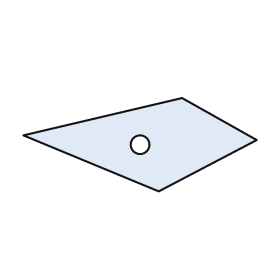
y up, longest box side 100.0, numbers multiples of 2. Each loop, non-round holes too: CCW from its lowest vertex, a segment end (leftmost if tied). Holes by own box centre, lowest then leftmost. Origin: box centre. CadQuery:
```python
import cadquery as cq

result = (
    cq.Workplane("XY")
    .moveTo(8.0, -20.0)
    .lineTo(50.0, 2.0)
    .lineTo(18.0, 20.0)
    .lineTo(-50.0, 4.0)
    .close()
    .moveTo(0.0, 0.0)
    .circle(4.0)
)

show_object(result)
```